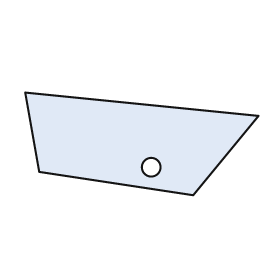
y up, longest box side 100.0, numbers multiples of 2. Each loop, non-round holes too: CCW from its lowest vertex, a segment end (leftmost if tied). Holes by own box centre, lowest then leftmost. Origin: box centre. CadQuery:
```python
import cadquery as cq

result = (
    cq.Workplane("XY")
    .moveTo(22.0, -22.0)
    .lineTo(50.0, 12.0)
    .lineTo(-50.0, 22.0)
    .lineTo(-44.0, -12.0)
    .close()
    .moveTo(4.0, -10.0)
    .circle(4.0)
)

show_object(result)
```